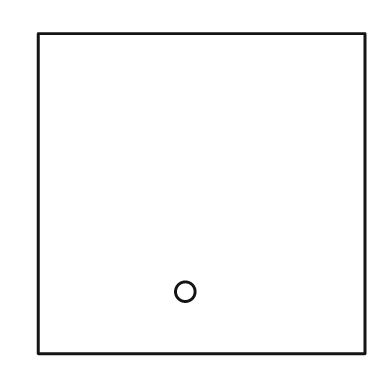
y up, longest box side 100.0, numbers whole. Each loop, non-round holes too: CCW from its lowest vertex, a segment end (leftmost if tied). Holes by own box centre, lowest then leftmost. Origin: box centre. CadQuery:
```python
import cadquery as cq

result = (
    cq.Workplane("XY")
    .moveTo(-50.0, -49.0)
    .lineTo(50.0, -49.0)
    .lineTo(50.0, 49.0)
    .lineTo(-50.0, 49.0)
    .close()
    .moveTo(-5.0, -30.0)
    .circle(3.0)
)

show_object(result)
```